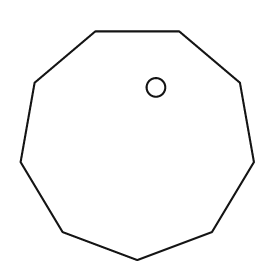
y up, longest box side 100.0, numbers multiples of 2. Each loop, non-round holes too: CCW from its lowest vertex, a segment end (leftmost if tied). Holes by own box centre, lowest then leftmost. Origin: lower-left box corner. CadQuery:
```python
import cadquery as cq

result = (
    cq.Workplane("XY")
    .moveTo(50.0, 0.0)
    .lineTo(82.0, 12.0)
    .lineTo(100.0, 42.0)
    .lineTo(94.0, 76.0)
    .lineTo(68.0, 98.0)
    .lineTo(32.0, 98.0)
    .lineTo(6.0, 76.0)
    .lineTo(0.0, 42.0)
    .lineTo(18.0, 12.0)
    .close()
    .moveTo(58.0, 74.0)
    .circle(4.0)
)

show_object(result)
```